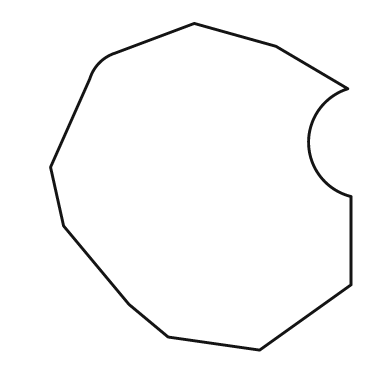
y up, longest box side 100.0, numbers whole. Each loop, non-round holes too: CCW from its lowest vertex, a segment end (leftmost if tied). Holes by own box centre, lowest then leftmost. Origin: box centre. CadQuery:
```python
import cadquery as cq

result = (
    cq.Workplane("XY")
    .moveTo(18.0, -50.0)
    .lineTo(46.0, -30.0)
    .lineTo(46.0, -3.0)
    .threePointArc((33.0, 13.0), (45.0, 30.0))
    .lineTo(23.0, 43.0)
    .lineTo(-2.0, 50.0)
    .lineTo(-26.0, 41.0)
    .threePointArc((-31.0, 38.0), (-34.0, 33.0))
    .lineTo(-46.0, 6.0)
    .lineTo(-42.0, -12.0)
    .lineTo(-22.0, -36.0)
    .lineTo(-10.0, -46.0)
    .close()
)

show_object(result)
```